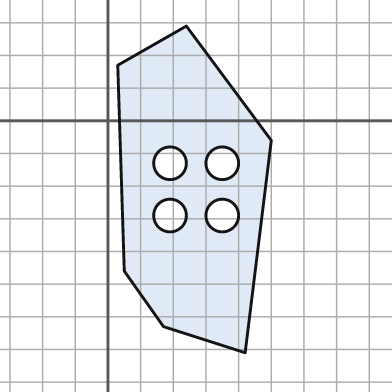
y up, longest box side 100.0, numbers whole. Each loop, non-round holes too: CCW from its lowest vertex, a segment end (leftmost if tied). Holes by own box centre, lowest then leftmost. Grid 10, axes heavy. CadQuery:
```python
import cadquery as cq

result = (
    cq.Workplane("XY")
    .moveTo(42.0, -71.0)
    .lineTo(50.0, -6.0)
    .lineTo(24.0, 29.0)
    .lineTo(3.0, 17.0)
    .lineTo(5.0, -46.0)
    .lineTo(17.0, -63.0)
    .close()
    .moveTo(19.0, -29.0)
    .circle(5.0)
    .moveTo(35.0, -29.0)
    .circle(5.0)
    .moveTo(19.0, -13.0)
    .circle(5.0)
    .moveTo(35.0, -13.0)
    .circle(5.0)
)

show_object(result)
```